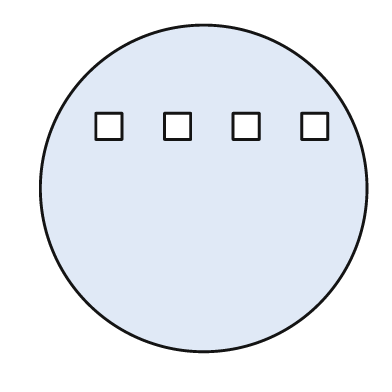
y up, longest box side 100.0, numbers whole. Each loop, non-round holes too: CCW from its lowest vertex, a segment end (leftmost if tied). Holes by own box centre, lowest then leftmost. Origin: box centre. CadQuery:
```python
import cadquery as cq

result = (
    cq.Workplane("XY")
    .moveTo(0.0, 0.0)
    .circle(50.0)
    .moveTo(-33.0, 15.0)
    .lineTo(-25.0, 15.0)
    .lineTo(-25.0, 23.0)
    .lineTo(-33.0, 23.0)
    .close()
    .moveTo(-12.0, 15.0)
    .lineTo(-4.0, 15.0)
    .lineTo(-4.0, 23.0)
    .lineTo(-12.0, 23.0)
    .close()
    .moveTo(9.0, 15.0)
    .lineTo(17.0, 15.0)
    .lineTo(17.0, 23.0)
    .lineTo(9.0, 23.0)
    .close()
    .moveTo(30.0, 15.0)
    .lineTo(38.0, 15.0)
    .lineTo(38.0, 23.0)
    .lineTo(30.0, 23.0)
    .close()
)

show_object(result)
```